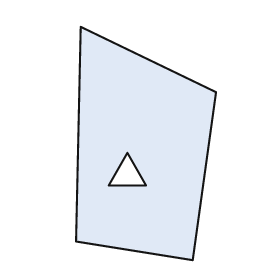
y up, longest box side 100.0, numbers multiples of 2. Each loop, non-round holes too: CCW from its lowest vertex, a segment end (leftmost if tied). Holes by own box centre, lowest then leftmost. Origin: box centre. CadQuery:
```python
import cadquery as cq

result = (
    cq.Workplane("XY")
    .moveTo(20.0, -50.0)
    .lineTo(30.0, 22.0)
    .lineTo(-28.0, 50.0)
    .lineTo(-30.0, -42.0)
    .close()
    .moveTo(-16.0, -18.0)
    .lineTo(0.0, -18.0)
    .lineTo(-8.0, -4.0)
    .close()
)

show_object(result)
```